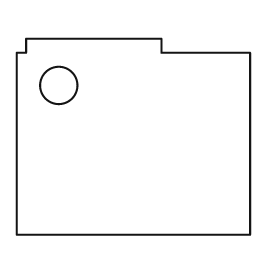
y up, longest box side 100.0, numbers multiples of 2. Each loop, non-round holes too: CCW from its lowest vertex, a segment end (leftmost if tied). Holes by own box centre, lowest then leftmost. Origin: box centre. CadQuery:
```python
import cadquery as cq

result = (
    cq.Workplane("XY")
    .moveTo(-50.0, -42.0)
    .lineTo(50.0, -42.0)
    .lineTo(50.0, 36.0)
    .lineTo(12.0, 36.0)
    .lineTo(12.0, 42.0)
    .lineTo(-46.0, 42.0)
    .lineTo(-46.0, 36.0)
    .lineTo(-50.0, 36.0)
    .close()
    .moveTo(-32.0, 22.0)
    .circle(8.0)
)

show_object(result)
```